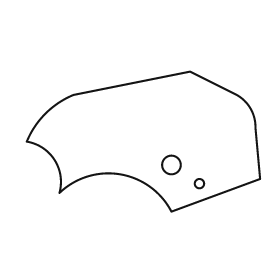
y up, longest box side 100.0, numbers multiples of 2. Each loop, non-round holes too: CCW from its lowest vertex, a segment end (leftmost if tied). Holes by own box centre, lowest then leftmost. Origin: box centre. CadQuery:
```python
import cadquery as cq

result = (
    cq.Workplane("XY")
    .moveTo(12.0, -30.0)
    .lineTo(50.0, -16.0)
    .lineTo(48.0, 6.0)
    .threePointArc((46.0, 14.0), (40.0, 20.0))
    .lineTo(20.0, 30.0)
    .lineTo(-30.0, 20.0)
    .threePointArc((-42.0, 12.0), (-50.0, 0.0))
    .threePointArc((-38.0, -8.0), (-36.0, -22.0))
    .threePointArc((-10.0, -14.0), (12.0, -30.0))
    .close()
    .moveTo(24.0, -18.0)
    .circle(2.0)
    .moveTo(12.0, -10.0)
    .circle(4.0)
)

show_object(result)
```